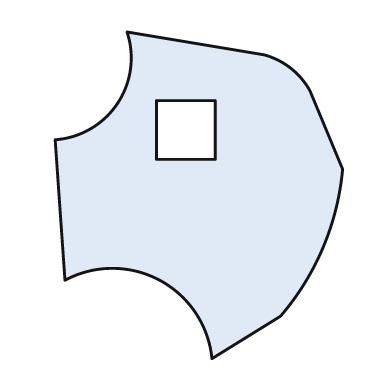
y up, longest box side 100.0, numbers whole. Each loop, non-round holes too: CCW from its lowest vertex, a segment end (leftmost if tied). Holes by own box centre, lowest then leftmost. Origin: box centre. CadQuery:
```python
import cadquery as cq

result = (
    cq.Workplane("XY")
    .moveTo(4.0, -50.0)
    .lineTo(25.0, -37.0)
    .threePointArc((38.0, -16.0), (44.0, 8.0))
    .lineTo(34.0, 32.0)
    .threePointArc((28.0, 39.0), (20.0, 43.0))
    .lineTo(-22.0, 50.0)
    .threePointArc((-25.0, 28.0), (-44.0, 17.0))
    .lineTo(-41.0, -26.0)
    .threePointArc((-12.0, -26.0), (4.0, -50.0))
    .close()
    .moveTo(-13.0, 11.0)
    .lineTo(5.0, 11.0)
    .lineTo(5.0, 29.0)
    .lineTo(-13.0, 29.0)
    .close()
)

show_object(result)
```